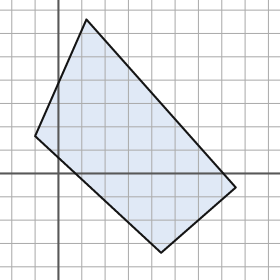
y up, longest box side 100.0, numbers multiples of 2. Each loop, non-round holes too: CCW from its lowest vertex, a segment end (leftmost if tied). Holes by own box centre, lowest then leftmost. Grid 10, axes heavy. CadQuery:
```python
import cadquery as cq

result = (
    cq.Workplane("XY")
    .moveTo(44.0, -34.0)
    .lineTo(76.0, -6.0)
    .lineTo(12.0, 66.0)
    .lineTo(-10.0, 16.0)
    .close()
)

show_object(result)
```